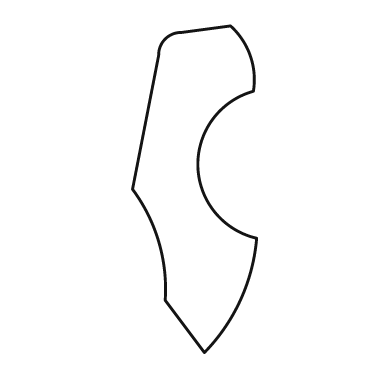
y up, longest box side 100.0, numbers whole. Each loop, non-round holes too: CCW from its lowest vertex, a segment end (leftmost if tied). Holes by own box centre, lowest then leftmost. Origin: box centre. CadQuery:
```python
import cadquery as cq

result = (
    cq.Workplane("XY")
    .moveTo(3.0, -50.0)
    .threePointArc((14.0, -34.0), (19.0, -15.0))
    .threePointArc((1.0, 7.0), (18.0, 30.0))
    .threePointArc((17.0, 41.0), (11.0, 50.0))
    .lineTo(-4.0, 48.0)
    .threePointArc((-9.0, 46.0), (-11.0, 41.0))
    .lineTo(-19.0, 0.0)
    .threePointArc((-11.0, -16.0), (-9.0, -34.0))
    .close()
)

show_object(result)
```